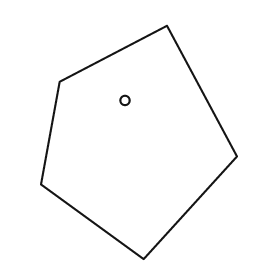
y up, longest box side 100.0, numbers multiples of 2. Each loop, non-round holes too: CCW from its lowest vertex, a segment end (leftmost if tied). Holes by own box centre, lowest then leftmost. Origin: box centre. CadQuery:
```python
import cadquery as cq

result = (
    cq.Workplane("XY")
    .moveTo(2.0, -50.0)
    .lineTo(42.0, -6.0)
    .lineTo(12.0, 50.0)
    .lineTo(-34.0, 26.0)
    .lineTo(-42.0, -18.0)
    .close()
    .moveTo(-6.0, 18.0)
    .circle(2.0)
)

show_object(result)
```